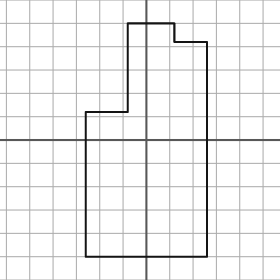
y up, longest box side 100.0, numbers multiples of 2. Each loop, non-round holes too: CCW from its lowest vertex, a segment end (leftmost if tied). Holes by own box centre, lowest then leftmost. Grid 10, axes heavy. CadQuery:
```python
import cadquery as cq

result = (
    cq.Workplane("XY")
    .moveTo(-26.0, -50.0)
    .lineTo(26.0, -50.0)
    .lineTo(26.0, 42.0)
    .lineTo(12.0, 42.0)
    .lineTo(12.0, 50.0)
    .lineTo(-8.0, 50.0)
    .lineTo(-8.0, 12.0)
    .lineTo(-26.0, 12.0)
    .close()
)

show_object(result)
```